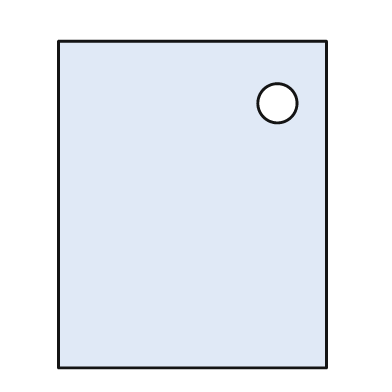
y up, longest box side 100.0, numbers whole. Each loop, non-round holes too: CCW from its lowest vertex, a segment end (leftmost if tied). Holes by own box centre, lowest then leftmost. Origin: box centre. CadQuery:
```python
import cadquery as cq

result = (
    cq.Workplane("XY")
    .moveTo(-41.0, -50.0)
    .lineTo(41.0, -50.0)
    .lineTo(41.0, 50.0)
    .lineTo(-41.0, 50.0)
    .close()
    .moveTo(26.0, 31.0)
    .circle(6.0)
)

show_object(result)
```